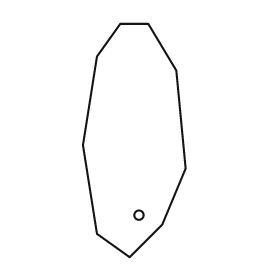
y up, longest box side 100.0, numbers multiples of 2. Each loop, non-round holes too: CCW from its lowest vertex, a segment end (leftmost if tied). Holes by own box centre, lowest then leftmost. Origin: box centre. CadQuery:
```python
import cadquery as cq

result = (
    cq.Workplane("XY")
    .moveTo(-2.0, -50.0)
    .lineTo(12.0, -36.0)
    .lineTo(22.0, -12.0)
    .lineTo(18.0, 30.0)
    .lineTo(6.0, 50.0)
    .lineTo(-6.0, 50.0)
    .lineTo(-16.0, 36.0)
    .lineTo(-22.0, -2.0)
    .lineTo(-16.0, -40.0)
    .close()
    .moveTo(2.0, -32.0)
    .circle(2.0)
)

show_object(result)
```